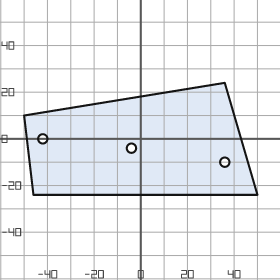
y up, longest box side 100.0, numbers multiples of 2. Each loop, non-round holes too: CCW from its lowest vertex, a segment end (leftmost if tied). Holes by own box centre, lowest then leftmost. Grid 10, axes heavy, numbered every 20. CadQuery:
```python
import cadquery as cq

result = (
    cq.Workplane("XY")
    .moveTo(-46.0, -24.0)
    .lineTo(50.0, -24.0)
    .lineTo(36.0, 24.0)
    .lineTo(-50.0, 10.0)
    .close()
    .moveTo(36.0, -10.0)
    .circle(2.0)
    .moveTo(-4.0, -4.0)
    .circle(2.0)
    .moveTo(-42.0, 0.0)
    .circle(2.0)
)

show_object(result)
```